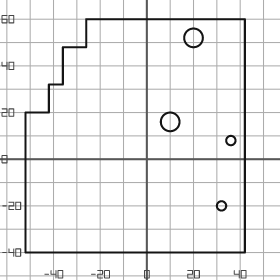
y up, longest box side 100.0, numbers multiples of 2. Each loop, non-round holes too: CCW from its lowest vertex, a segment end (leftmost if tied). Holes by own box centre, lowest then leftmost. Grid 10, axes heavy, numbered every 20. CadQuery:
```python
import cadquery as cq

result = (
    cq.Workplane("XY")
    .moveTo(-52.0, -40.0)
    .lineTo(42.0, -40.0)
    .lineTo(42.0, 60.0)
    .lineTo(-26.0, 60.0)
    .lineTo(-26.0, 48.0)
    .lineTo(-36.0, 48.0)
    .lineTo(-36.0, 32.0)
    .lineTo(-42.0, 32.0)
    .lineTo(-42.0, 20.0)
    .lineTo(-52.0, 20.0)
    .close()
    .moveTo(32.0, -20.0)
    .circle(2.0)
    .moveTo(36.0, 8.0)
    .circle(2.0)
    .moveTo(10.0, 16.0)
    .circle(4.0)
    .moveTo(20.0, 52.0)
    .circle(4.0)
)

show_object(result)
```